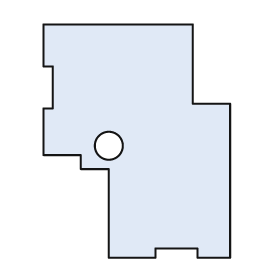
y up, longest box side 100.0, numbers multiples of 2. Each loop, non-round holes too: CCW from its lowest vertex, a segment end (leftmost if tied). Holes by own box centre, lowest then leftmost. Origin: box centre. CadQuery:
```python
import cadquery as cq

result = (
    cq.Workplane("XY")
    .moveTo(-12.0, -50.0)
    .lineTo(8.0, -50.0)
    .lineTo(8.0, -46.0)
    .lineTo(26.0, -46.0)
    .lineTo(26.0, -50.0)
    .lineTo(40.0, -50.0)
    .lineTo(40.0, 16.0)
    .lineTo(24.0, 16.0)
    .lineTo(24.0, 50.0)
    .lineTo(-40.0, 50.0)
    .lineTo(-40.0, 32.0)
    .lineTo(-36.0, 32.0)
    .lineTo(-36.0, 14.0)
    .lineTo(-40.0, 14.0)
    .lineTo(-40.0, -6.0)
    .lineTo(-24.0, -6.0)
    .lineTo(-24.0, -12.0)
    .lineTo(-12.0, -12.0)
    .close()
    .moveTo(-12.0, -2.0)
    .circle(6.0)
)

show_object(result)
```